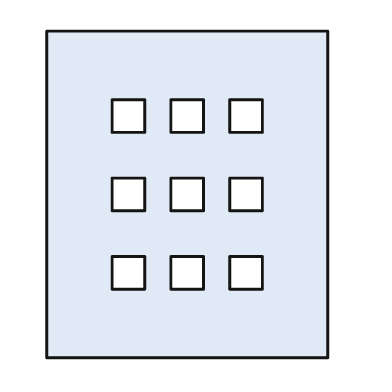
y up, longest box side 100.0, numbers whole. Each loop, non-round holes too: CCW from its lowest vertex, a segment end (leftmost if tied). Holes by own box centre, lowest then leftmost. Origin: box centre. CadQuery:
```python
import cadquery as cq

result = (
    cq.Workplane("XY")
    .moveTo(-43.0, -50.0)
    .lineTo(43.0, -50.0)
    .lineTo(43.0, 50.0)
    .lineTo(-43.0, 50.0)
    .close()
    .moveTo(-23.0, -29.0)
    .lineTo(-13.0, -29.0)
    .lineTo(-13.0, -19.0)
    .lineTo(-23.0, -19.0)
    .close()
    .moveTo(-5.0, -29.0)
    .lineTo(5.0, -29.0)
    .lineTo(5.0, -19.0)
    .lineTo(-5.0, -19.0)
    .close()
    .moveTo(13.0, -29.0)
    .lineTo(23.0, -29.0)
    .lineTo(23.0, -19.0)
    .lineTo(13.0, -19.0)
    .close()
    .moveTo(-23.0, -5.0)
    .lineTo(-13.0, -5.0)
    .lineTo(-13.0, 5.0)
    .lineTo(-23.0, 5.0)
    .close()
    .moveTo(-5.0, -5.0)
    .lineTo(5.0, -5.0)
    .lineTo(5.0, 5.0)
    .lineTo(-5.0, 5.0)
    .close()
    .moveTo(13.0, -5.0)
    .lineTo(23.0, -5.0)
    .lineTo(23.0, 5.0)
    .lineTo(13.0, 5.0)
    .close()
    .moveTo(-23.0, 19.0)
    .lineTo(-13.0, 19.0)
    .lineTo(-13.0, 29.0)
    .lineTo(-23.0, 29.0)
    .close()
    .moveTo(-5.0, 19.0)
    .lineTo(5.0, 19.0)
    .lineTo(5.0, 29.0)
    .lineTo(-5.0, 29.0)
    .close()
    .moveTo(13.0, 19.0)
    .lineTo(23.0, 19.0)
    .lineTo(23.0, 29.0)
    .lineTo(13.0, 29.0)
    .close()
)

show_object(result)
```